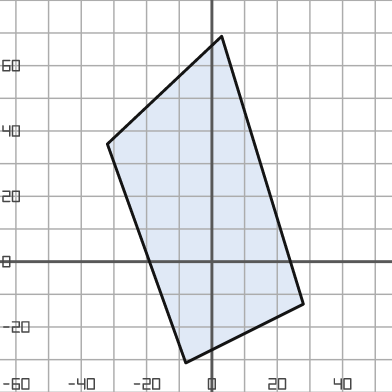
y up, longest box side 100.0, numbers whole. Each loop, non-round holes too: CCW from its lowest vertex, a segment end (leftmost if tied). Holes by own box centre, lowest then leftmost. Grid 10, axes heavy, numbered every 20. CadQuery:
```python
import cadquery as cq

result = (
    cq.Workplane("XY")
    .moveTo(-8.0, -31.0)
    .lineTo(28.0, -13.0)
    .lineTo(3.0, 69.0)
    .lineTo(-32.0, 36.0)
    .close()
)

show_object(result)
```